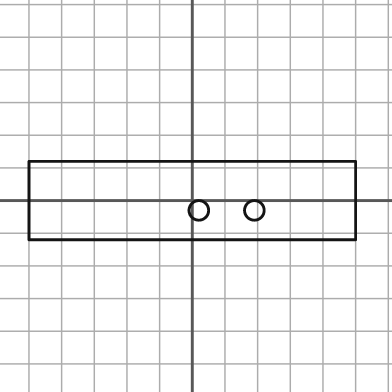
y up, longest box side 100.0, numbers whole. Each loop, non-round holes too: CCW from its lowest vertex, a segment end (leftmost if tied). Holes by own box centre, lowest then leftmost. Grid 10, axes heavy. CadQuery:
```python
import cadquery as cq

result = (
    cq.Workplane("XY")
    .moveTo(-50.0, -12.0)
    .lineTo(50.0, -12.0)
    .lineTo(50.0, 12.0)
    .lineTo(-50.0, 12.0)
    .close()
    .moveTo(2.0, -3.0)
    .circle(3.0)
    .moveTo(19.0, -3.0)
    .circle(3.0)
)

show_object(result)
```